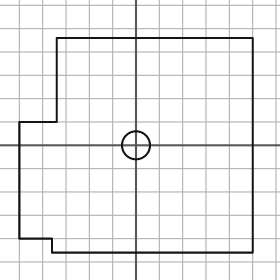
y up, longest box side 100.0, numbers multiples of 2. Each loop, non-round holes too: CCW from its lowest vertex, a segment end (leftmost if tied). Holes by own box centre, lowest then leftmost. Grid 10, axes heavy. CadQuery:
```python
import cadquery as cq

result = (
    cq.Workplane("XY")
    .moveTo(-36.0, -46.0)
    .lineTo(50.0, -46.0)
    .lineTo(50.0, 46.0)
    .lineTo(-34.0, 46.0)
    .lineTo(-34.0, 10.0)
    .lineTo(-50.0, 10.0)
    .lineTo(-50.0, -40.0)
    .lineTo(-36.0, -40.0)
    .close()
    .moveTo(0.0, 0.0)
    .circle(6.0)
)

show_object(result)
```